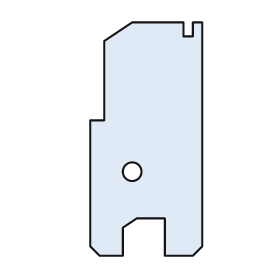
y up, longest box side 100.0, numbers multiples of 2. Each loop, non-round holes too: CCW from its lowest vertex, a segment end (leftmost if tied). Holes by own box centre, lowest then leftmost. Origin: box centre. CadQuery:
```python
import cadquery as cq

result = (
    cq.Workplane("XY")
    .moveTo(-20.0, -50.0)
    .lineTo(-10.0, -50.0)
    .lineTo(-10.0, -38.0)
    .lineTo(-4.0, -34.0)
    .lineTo(8.0, -34.0)
    .lineTo(8.0, -50.0)
    .lineTo(20.0, -50.0)
    .lineTo(24.0, -46.0)
    .lineTo(24.0, 50.0)
    .lineTo(20.0, 50.0)
    .lineTo(20.0, 44.0)
    .lineTo(16.0, 44.0)
    .lineTo(16.0, 50.0)
    .lineTo(-6.0, 50.0)
    .lineTo(-18.0, 42.0)
    .lineTo(-18.0, 8.0)
    .lineTo(-24.0, 8.0)
    .lineTo(-24.0, -46.0)
    .close()
    .moveTo(-6.0, -14.0)
    .circle(4.0)
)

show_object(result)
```